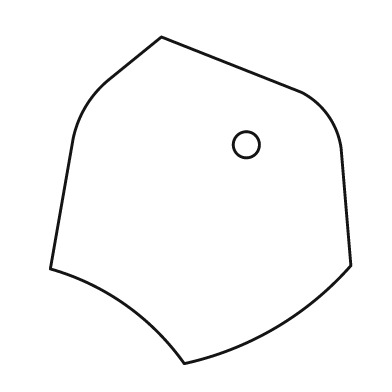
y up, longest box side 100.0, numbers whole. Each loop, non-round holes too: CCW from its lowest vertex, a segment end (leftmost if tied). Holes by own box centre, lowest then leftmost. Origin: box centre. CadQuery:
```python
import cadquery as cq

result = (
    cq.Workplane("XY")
    .moveTo(-5.0, -50.0)
    .threePointArc((23.0, -39.0), (46.0, -20.0))
    .lineTo(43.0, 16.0)
    .threePointArc((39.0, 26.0), (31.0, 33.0))
    .lineTo(-12.0, 50.0)
    .lineTo(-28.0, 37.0)
    .threePointArc((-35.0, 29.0), (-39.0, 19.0))
    .lineTo(-46.0, -21.0)
    .threePointArc((-23.0, -32.0), (-5.0, -50.0))
    .close()
    .moveTo(14.0, 17.0)
    .circle(4.0)
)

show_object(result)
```